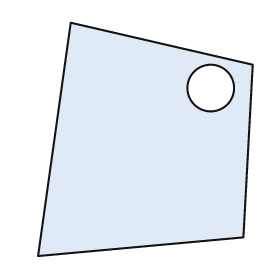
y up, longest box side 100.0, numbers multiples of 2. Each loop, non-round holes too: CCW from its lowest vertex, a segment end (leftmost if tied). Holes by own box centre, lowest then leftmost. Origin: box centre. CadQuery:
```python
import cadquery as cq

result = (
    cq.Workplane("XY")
    .moveTo(-46.0, -50.0)
    .lineTo(42.0, -42.0)
    .lineTo(46.0, 32.0)
    .lineTo(-32.0, 50.0)
    .close()
    .moveTo(28.0, 22.0)
    .circle(10.0)
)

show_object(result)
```